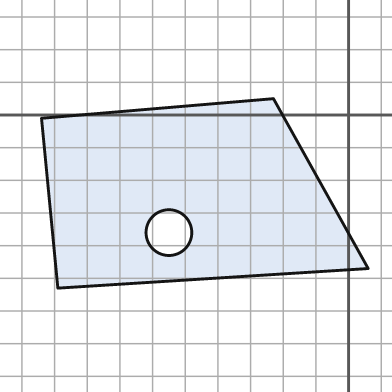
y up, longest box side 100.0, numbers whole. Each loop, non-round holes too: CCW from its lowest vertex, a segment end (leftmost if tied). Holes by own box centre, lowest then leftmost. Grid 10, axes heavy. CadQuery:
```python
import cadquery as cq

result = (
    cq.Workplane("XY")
    .moveTo(-89.0, -53.0)
    .lineTo(6.0, -47.0)
    .lineTo(-23.0, 5.0)
    .lineTo(-94.0, -1.0)
    .close()
    .moveTo(-55.0, -36.0)
    .circle(7.0)
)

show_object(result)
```